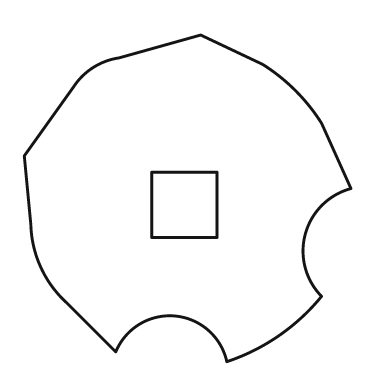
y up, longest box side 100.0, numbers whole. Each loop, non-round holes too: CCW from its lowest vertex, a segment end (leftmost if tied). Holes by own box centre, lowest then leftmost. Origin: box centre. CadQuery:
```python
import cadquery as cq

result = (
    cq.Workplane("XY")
    .moveTo(12.0, -50.0)
    .threePointArc((28.0, -42.0), (41.0, -30.0))
    .threePointArc((36.0, -11.0), (50.0, 3.0))
    .lineTo(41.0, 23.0)
    .threePointArc((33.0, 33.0), (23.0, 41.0))
    .lineTo(4.0, 50.0)
    .lineTo(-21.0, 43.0)
    .threePointArc((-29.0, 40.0), (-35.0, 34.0))
    .lineTo(-50.0, 13.0)
    .lineTo(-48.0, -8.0)
    .threePointArc((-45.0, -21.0), (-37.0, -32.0))
    .lineTo(-22.0, -47.0)
    .threePointArc((-4.0, -36.0), (12.0, -50.0))
    .close()
    .moveTo(-11.0, -12.0)
    .lineTo(9.0, -12.0)
    .lineTo(9.0, 8.0)
    .lineTo(-11.0, 8.0)
    .close()
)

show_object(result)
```